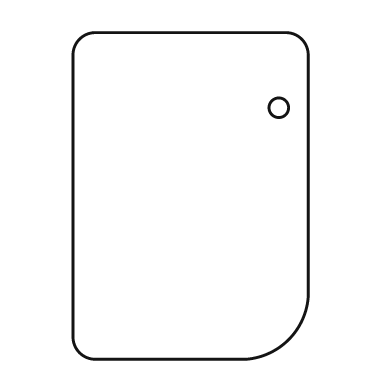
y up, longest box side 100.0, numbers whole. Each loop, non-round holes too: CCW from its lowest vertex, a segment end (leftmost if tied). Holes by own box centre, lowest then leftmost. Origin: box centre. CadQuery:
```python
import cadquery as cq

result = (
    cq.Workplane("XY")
    .moveTo(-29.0, -50.0)
    .lineTo(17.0, -50.0)
    .threePointArc((30.0, -44.0), (36.0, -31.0))
    .lineTo(36.0, 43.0)
    .threePointArc((34.0, 48.0), (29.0, 50.0))
    .lineTo(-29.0, 50.0)
    .threePointArc((-34.0, 48.0), (-36.0, 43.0))
    .lineTo(-36.0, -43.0)
    .threePointArc((-34.0, -48.0), (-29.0, -50.0))
    .close()
    .moveTo(27.0, 27.0)
    .circle(3.0)
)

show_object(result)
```